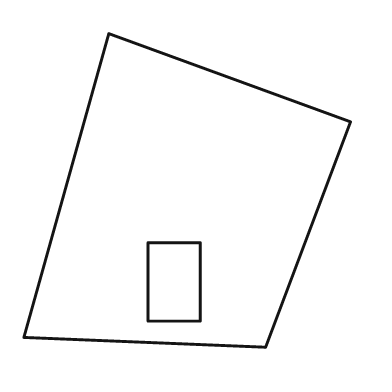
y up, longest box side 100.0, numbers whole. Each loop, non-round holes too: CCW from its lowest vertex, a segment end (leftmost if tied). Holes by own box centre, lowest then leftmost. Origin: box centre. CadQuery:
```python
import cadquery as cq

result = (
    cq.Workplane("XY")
    .moveTo(24.0, -48.0)
    .lineTo(50.0, 21.0)
    .lineTo(-24.0, 48.0)
    .lineTo(-50.0, -45.0)
    .close()
    .moveTo(-12.0, -40.0)
    .lineTo(4.0, -40.0)
    .lineTo(4.0, -16.0)
    .lineTo(-12.0, -16.0)
    .close()
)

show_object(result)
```